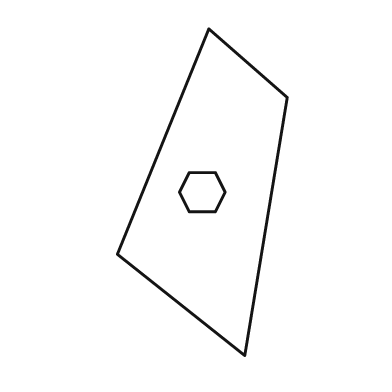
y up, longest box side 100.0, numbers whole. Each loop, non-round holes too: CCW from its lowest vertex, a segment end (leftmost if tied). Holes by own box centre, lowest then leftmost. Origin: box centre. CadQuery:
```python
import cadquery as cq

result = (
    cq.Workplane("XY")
    .moveTo(13.0, -50.0)
    .lineTo(26.0, 29.0)
    .lineTo(2.0, 50.0)
    .lineTo(-26.0, -19.0)
    .close()
    .moveTo(-4.0, -6.0)
    .lineTo(4.0, -6.0)
    .lineTo(7.0, 0.0)
    .lineTo(4.0, 6.0)
    .lineTo(-4.0, 6.0)
    .lineTo(-7.0, 0.0)
    .close()
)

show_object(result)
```